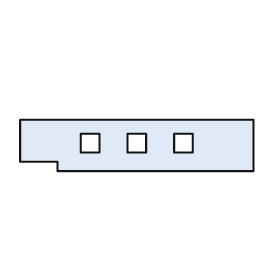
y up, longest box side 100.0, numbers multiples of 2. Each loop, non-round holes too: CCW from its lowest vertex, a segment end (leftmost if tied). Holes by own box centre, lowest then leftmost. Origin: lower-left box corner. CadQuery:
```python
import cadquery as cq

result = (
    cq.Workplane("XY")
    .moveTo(16.0, 0.0)
    .lineTo(100.0, 0.0)
    .lineTo(100.0, 22.0)
    .lineTo(0.0, 22.0)
    .lineTo(0.0, 4.0)
    .lineTo(16.0, 4.0)
    .close()
    .moveTo(26.0, 8.0)
    .lineTo(34.0, 8.0)
    .lineTo(34.0, 16.0)
    .lineTo(26.0, 16.0)
    .close()
    .moveTo(46.0, 8.0)
    .lineTo(54.0, 8.0)
    .lineTo(54.0, 16.0)
    .lineTo(46.0, 16.0)
    .close()
    .moveTo(66.0, 8.0)
    .lineTo(74.0, 8.0)
    .lineTo(74.0, 16.0)
    .lineTo(66.0, 16.0)
    .close()
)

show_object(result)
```